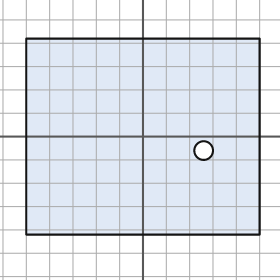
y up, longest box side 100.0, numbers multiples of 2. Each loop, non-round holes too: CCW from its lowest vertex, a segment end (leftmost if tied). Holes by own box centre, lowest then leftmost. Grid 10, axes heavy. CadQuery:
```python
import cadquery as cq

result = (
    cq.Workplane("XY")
    .moveTo(-50.0, -42.0)
    .lineTo(50.0, -42.0)
    .lineTo(50.0, 42.0)
    .lineTo(-50.0, 42.0)
    .close()
    .moveTo(26.0, -6.0)
    .circle(4.0)
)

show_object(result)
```